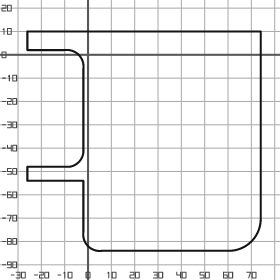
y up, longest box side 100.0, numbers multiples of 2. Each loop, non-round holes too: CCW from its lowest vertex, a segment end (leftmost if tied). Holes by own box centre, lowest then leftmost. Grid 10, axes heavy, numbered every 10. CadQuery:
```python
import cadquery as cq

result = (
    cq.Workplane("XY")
    .moveTo(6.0, -84.0)
    .lineTo(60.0, -84.0)
    .threePointArc((70.0, -80.0), (74.0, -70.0))
    .lineTo(74.0, 10.0)
    .lineTo(-26.0, 10.0)
    .lineTo(-26.0, 2.0)
    .lineTo(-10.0, 2.0)
    .threePointArc((-4.0, 0.0), (-2.0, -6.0))
    .lineTo(-2.0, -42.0)
    .threePointArc((-4.0, -46.0), (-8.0, -48.0))
    .lineTo(-26.0, -48.0)
    .lineTo(-26.0, -54.0)
    .lineTo(-2.0, -54.0)
    .lineTo(-2.0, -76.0)
    .threePointArc((0.0, -82.0), (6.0, -84.0))
    .close()
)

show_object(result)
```